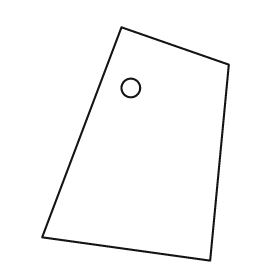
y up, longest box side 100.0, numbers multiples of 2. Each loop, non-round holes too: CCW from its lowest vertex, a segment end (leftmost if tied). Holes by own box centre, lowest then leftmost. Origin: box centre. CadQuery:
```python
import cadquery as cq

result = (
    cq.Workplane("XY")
    .moveTo(32.0, -50.0)
    .lineTo(40.0, 34.0)
    .lineTo(-6.0, 50.0)
    .lineTo(-40.0, -40.0)
    .close()
    .moveTo(-2.0, 24.0)
    .circle(4.0)
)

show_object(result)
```